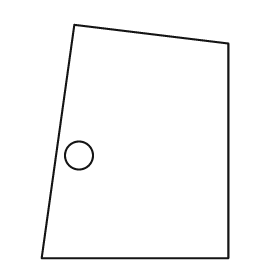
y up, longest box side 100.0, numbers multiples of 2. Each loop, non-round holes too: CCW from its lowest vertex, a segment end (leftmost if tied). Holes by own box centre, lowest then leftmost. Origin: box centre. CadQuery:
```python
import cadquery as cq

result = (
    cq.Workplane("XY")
    .moveTo(-40.0, -50.0)
    .lineTo(40.0, -50.0)
    .lineTo(40.0, 42.0)
    .lineTo(-26.0, 50.0)
    .close()
    .moveTo(-24.0, -6.0)
    .circle(6.0)
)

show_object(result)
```